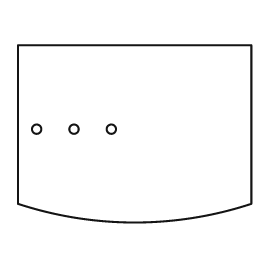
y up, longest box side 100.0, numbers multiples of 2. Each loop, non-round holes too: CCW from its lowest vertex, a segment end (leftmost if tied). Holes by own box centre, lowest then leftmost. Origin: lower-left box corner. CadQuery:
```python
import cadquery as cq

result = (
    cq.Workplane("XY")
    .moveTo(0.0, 8.0)
    .threePointArc((50.0, 0.0), (100.0, 8.0))
    .lineTo(100.0, 76.0)
    .lineTo(0.0, 76.0)
    .close()
    .moveTo(8.0, 40.0)
    .circle(2.0)
    .moveTo(24.0, 40.0)
    .circle(2.0)
    .moveTo(40.0, 40.0)
    .circle(2.0)
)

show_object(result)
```